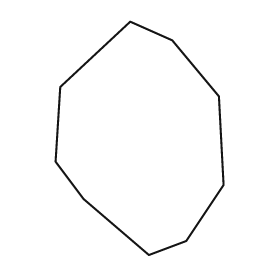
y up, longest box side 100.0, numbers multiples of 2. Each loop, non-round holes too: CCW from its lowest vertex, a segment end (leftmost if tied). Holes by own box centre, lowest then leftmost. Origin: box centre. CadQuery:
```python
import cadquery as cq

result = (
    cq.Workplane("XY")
    .moveTo(4.0, -50.0)
    .lineTo(20.0, -44.0)
    .lineTo(36.0, -20.0)
    .lineTo(34.0, 18.0)
    .lineTo(14.0, 42.0)
    .lineTo(-4.0, 50.0)
    .lineTo(-34.0, 22.0)
    .lineTo(-36.0, -10.0)
    .lineTo(-24.0, -26.0)
    .close()
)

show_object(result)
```